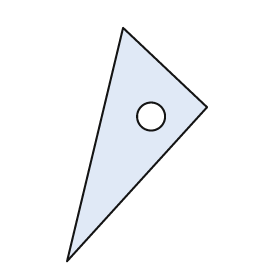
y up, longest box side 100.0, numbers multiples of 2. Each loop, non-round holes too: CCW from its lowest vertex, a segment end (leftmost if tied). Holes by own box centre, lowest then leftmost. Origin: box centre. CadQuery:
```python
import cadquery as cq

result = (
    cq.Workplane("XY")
    .moveTo(-30.0, -50.0)
    .lineTo(30.0, 16.0)
    .lineTo(-6.0, 50.0)
    .close()
    .moveTo(6.0, 12.0)
    .circle(6.0)
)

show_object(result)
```